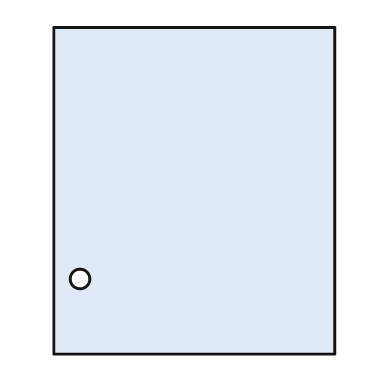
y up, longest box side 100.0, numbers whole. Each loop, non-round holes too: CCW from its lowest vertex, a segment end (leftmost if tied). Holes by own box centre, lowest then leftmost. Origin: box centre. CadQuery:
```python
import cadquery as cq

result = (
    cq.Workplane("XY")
    .moveTo(-43.0, -50.0)
    .lineTo(43.0, -50.0)
    .lineTo(43.0, 50.0)
    .lineTo(-43.0, 50.0)
    .close()
    .moveTo(-35.0, -27.0)
    .circle(3.0)
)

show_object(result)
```